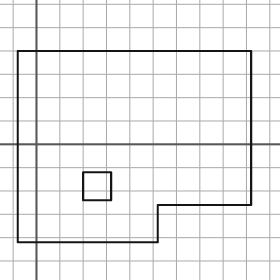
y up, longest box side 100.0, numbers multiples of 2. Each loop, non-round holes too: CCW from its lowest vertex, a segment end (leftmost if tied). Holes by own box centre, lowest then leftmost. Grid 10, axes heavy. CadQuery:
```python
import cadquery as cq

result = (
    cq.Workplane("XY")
    .moveTo(-8.0, -42.0)
    .lineTo(52.0, -42.0)
    .lineTo(52.0, -26.0)
    .lineTo(92.0, -26.0)
    .lineTo(92.0, 40.0)
    .lineTo(-8.0, 40.0)
    .close()
    .moveTo(20.0, -24.0)
    .lineTo(32.0, -24.0)
    .lineTo(32.0, -12.0)
    .lineTo(20.0, -12.0)
    .close()
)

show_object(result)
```